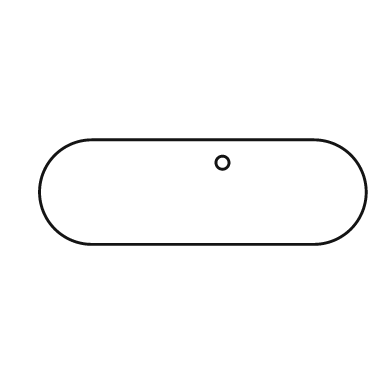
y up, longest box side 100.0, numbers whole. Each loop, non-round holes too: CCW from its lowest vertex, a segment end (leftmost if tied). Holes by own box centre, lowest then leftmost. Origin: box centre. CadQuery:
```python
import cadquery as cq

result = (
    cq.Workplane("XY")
    .moveTo(-34.0, -16.0)
    .lineTo(34.0, -16.0)
    .threePointArc((50.0, 0.0), (34.0, 16.0))
    .lineTo(-34.0, 16.0)
    .threePointArc((-50.0, 0.0), (-34.0, -16.0))
    .close()
    .moveTo(6.0, 9.0)
    .circle(2.0)
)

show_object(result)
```